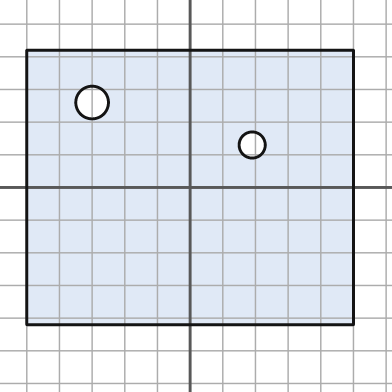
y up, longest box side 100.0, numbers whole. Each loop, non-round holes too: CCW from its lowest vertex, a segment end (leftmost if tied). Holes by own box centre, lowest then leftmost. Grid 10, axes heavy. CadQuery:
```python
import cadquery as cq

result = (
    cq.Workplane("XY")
    .moveTo(-50.0, -42.0)
    .lineTo(50.0, -42.0)
    .lineTo(50.0, 42.0)
    .lineTo(-50.0, 42.0)
    .close()
    .moveTo(19.0, 13.0)
    .circle(4.0)
    .moveTo(-30.0, 26.0)
    .circle(5.0)
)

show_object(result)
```